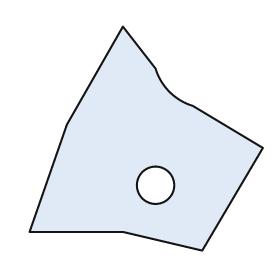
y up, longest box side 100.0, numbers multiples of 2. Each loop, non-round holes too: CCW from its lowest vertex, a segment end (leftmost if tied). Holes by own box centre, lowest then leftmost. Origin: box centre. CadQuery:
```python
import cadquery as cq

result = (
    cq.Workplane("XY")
    .moveTo(24.0, -48.0)
    .lineTo(50.0, -4.0)
    .lineTo(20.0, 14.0)
    .threePointArc((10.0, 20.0), (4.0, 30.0))
    .lineTo(-10.0, 48.0)
    .lineTo(-34.0, 6.0)
    .lineTo(-50.0, -40.0)
    .lineTo(-10.0, -40.0)
    .close()
    .moveTo(4.0, -20.0)
    .circle(8.0)
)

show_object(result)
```